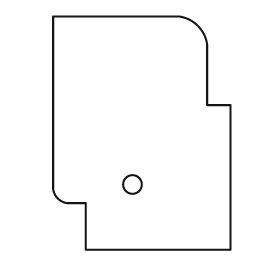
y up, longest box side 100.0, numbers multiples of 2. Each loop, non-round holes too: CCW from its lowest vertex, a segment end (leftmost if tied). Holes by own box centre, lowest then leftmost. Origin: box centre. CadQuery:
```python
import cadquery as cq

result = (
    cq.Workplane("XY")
    .moveTo(-24.0, -50.0)
    .lineTo(38.0, -50.0)
    .lineTo(38.0, 12.0)
    .lineTo(28.0, 12.0)
    .lineTo(28.0, 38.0)
    .threePointArc((24.0, 46.0), (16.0, 50.0))
    .lineTo(-38.0, 50.0)
    .lineTo(-38.0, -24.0)
    .threePointArc((-36.0, -28.0), (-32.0, -30.0))
    .lineTo(-24.0, -30.0)
    .close()
    .moveTo(-4.0, -22.0)
    .circle(4.0)
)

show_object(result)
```